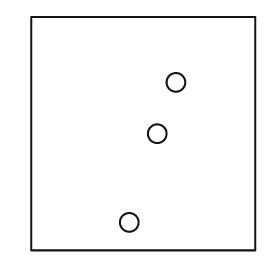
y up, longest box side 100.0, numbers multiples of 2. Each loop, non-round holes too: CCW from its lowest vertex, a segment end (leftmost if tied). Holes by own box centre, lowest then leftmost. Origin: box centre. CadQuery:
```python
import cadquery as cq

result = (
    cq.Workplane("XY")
    .moveTo(-48.0, -50.0)
    .lineTo(48.0, -50.0)
    .lineTo(48.0, 50.0)
    .lineTo(-48.0, 50.0)
    .close()
    .moveTo(-6.0, -38.0)
    .circle(4.0)
    .moveTo(6.0, 0.0)
    .circle(4.0)
    .moveTo(14.0, 22.0)
    .circle(4.0)
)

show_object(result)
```